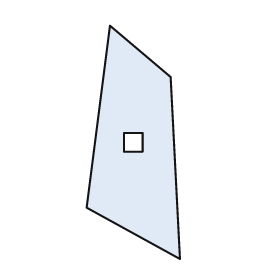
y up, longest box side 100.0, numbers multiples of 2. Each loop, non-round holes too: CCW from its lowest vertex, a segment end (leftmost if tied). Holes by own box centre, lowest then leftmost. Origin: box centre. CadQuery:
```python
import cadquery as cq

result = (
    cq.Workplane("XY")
    .moveTo(20.0, -50.0)
    .lineTo(16.0, 28.0)
    .lineTo(-10.0, 50.0)
    .lineTo(-20.0, -28.0)
    .close()
    .moveTo(-4.0, -4.0)
    .lineTo(4.0, -4.0)
    .lineTo(4.0, 4.0)
    .lineTo(-4.0, 4.0)
    .close()
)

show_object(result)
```